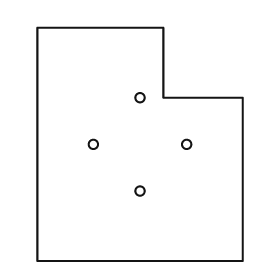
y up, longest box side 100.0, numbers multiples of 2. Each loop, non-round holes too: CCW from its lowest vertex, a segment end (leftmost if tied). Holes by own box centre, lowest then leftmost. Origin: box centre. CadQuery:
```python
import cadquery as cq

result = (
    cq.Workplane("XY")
    .moveTo(-44.0, -50.0)
    .lineTo(44.0, -50.0)
    .lineTo(44.0, 20.0)
    .lineTo(10.0, 20.0)
    .lineTo(10.0, 50.0)
    .lineTo(-44.0, 50.0)
    .close()
    .moveTo(0.0, -20.0)
    .circle(2.0)
    .moveTo(-20.0, 0.0)
    .circle(2.0)
    .moveTo(20.0, 0.0)
    .circle(2.0)
    .moveTo(0.0, 20.0)
    .circle(2.0)
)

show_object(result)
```